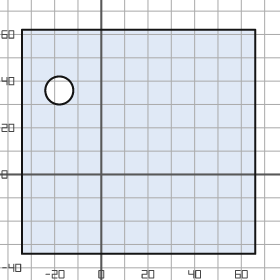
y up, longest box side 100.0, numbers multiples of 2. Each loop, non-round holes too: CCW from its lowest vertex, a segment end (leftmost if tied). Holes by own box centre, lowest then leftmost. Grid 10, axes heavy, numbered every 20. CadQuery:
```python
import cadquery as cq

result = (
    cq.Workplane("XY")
    .moveTo(-34.0, -34.0)
    .lineTo(66.0, -34.0)
    .lineTo(66.0, 62.0)
    .lineTo(-34.0, 62.0)
    .close()
    .moveTo(-18.0, 36.0)
    .circle(6.0)
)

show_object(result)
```